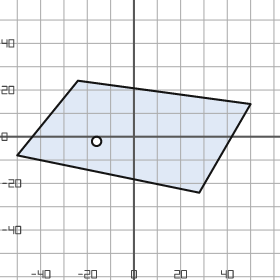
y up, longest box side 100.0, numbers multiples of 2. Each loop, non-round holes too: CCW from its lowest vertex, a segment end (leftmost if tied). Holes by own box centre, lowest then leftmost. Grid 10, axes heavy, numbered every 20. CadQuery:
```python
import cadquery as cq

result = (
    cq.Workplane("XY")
    .moveTo(28.0, -24.0)
    .lineTo(50.0, 14.0)
    .lineTo(-24.0, 24.0)
    .lineTo(-50.0, -8.0)
    .close()
    .moveTo(-16.0, -2.0)
    .circle(2.0)
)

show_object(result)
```